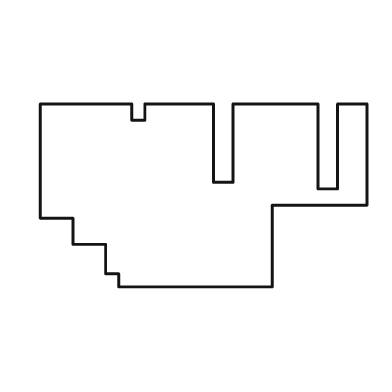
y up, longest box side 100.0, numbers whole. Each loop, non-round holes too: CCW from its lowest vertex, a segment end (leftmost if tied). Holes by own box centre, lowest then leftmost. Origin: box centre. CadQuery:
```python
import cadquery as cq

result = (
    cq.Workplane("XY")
    .moveTo(-26.0, -28.0)
    .lineTo(21.0, -28.0)
    .lineTo(21.0, -3.0)
    .lineTo(50.0, -3.0)
    .lineTo(50.0, 28.0)
    .lineTo(41.0, 28.0)
    .lineTo(41.0, 2.0)
    .lineTo(35.0, 2.0)
    .lineTo(35.0, 28.0)
    .lineTo(9.0, 28.0)
    .lineTo(9.0, 4.0)
    .lineTo(3.0, 4.0)
    .lineTo(3.0, 28.0)
    .lineTo(-18.0, 28.0)
    .lineTo(-18.0, 23.0)
    .lineTo(-22.0, 23.0)
    .lineTo(-22.0, 28.0)
    .lineTo(-50.0, 28.0)
    .lineTo(-50.0, -7.0)
    .lineTo(-40.0, -7.0)
    .lineTo(-40.0, -15.0)
    .lineTo(-30.0, -15.0)
    .lineTo(-30.0, -24.0)
    .lineTo(-26.0, -24.0)
    .close()
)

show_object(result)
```